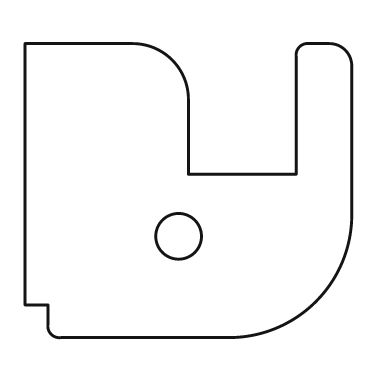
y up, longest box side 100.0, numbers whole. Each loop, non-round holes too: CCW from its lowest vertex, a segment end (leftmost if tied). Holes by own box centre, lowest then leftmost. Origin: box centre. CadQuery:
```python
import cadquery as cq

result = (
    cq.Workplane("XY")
    .moveTo(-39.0, -45.0)
    .lineTo(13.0, -45.0)
    .threePointArc((39.0, -34.0), (50.0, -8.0))
    .lineTo(50.0, 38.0)
    .threePointArc((48.0, 43.0), (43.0, 45.0))
    .lineTo(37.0, 45.0)
    .threePointArc((34.0, 44.0), (33.0, 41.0))
    .lineTo(33.0, 5.0)
    .lineTo(0.0, 5.0)
    .lineTo(0.0, 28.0)
    .threePointArc((-5.0, 40.0), (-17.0, 45.0))
    .lineTo(-50.0, 45.0)
    .lineTo(-50.0, -35.0)
    .lineTo(-43.0, -35.0)
    .lineTo(-43.0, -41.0)
    .threePointArc((-42.0, -44.0), (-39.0, -45.0))
    .close()
    .moveTo(-3.0, -14.0)
    .circle(7.0)
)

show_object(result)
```